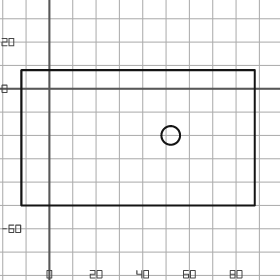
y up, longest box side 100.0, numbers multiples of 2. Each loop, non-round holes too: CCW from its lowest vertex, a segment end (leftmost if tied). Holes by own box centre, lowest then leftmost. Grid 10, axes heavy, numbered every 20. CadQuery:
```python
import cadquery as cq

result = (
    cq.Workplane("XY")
    .moveTo(-12.0, -50.0)
    .lineTo(88.0, -50.0)
    .lineTo(88.0, 8.0)
    .lineTo(-12.0, 8.0)
    .close()
    .moveTo(52.0, -20.0)
    .circle(4.0)
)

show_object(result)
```